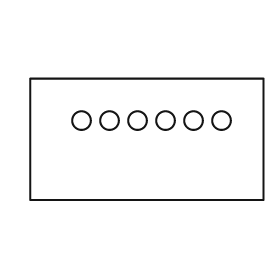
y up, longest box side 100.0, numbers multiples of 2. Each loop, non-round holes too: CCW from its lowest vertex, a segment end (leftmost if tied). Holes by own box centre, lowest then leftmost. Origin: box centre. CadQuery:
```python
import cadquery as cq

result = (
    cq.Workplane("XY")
    .moveTo(-50.0, -26.0)
    .lineTo(50.0, -26.0)
    .lineTo(50.0, 26.0)
    .lineTo(-50.0, 26.0)
    .close()
    .moveTo(-28.0, 8.0)
    .circle(4.0)
    .moveTo(-16.0, 8.0)
    .circle(4.0)
    .moveTo(-4.0, 8.0)
    .circle(4.0)
    .moveTo(8.0, 8.0)
    .circle(4.0)
    .moveTo(20.0, 8.0)
    .circle(4.0)
    .moveTo(32.0, 8.0)
    .circle(4.0)
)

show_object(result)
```